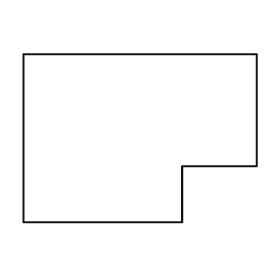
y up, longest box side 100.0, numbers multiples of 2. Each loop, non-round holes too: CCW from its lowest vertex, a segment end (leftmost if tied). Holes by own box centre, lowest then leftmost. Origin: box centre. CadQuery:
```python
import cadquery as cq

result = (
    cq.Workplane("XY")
    .moveTo(-50.0, -36.0)
    .lineTo(18.0, -36.0)
    .lineTo(18.0, -12.0)
    .lineTo(50.0, -12.0)
    .lineTo(50.0, 36.0)
    .lineTo(-50.0, 36.0)
    .close()
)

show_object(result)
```